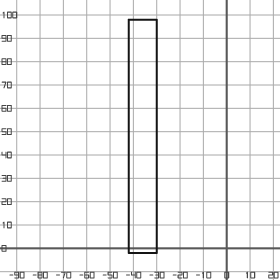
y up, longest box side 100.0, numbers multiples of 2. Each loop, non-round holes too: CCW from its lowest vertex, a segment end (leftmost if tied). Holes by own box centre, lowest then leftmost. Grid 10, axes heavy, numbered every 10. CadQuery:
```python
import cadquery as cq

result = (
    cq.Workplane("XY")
    .moveTo(-42.0, -2.0)
    .lineTo(-30.0, -2.0)
    .lineTo(-30.0, 98.0)
    .lineTo(-42.0, 98.0)
    .close()
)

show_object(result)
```